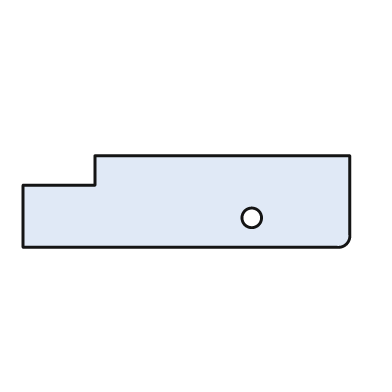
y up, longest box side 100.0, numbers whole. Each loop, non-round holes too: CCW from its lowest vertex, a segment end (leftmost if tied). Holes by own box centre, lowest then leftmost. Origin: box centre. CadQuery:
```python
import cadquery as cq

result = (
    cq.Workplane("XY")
    .moveTo(-50.0, -14.0)
    .lineTo(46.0, -14.0)
    .threePointArc((49.0, -13.0), (50.0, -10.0))
    .lineTo(50.0, 14.0)
    .lineTo(-28.0, 14.0)
    .lineTo(-28.0, 5.0)
    .lineTo(-50.0, 5.0)
    .close()
    .moveTo(20.0, -5.0)
    .circle(3.0)
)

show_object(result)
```